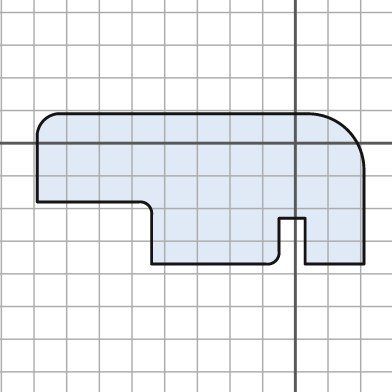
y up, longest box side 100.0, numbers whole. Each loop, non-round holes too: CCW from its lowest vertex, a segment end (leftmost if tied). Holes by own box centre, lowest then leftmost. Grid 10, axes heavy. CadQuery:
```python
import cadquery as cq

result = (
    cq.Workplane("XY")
    .moveTo(-44.0, -37.0)
    .lineTo(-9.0, -37.0)
    .threePointArc((-6.0, -36.0), (-5.0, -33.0))
    .lineTo(-5.0, -23.0)
    .lineTo(3.0, -23.0)
    .lineTo(3.0, -37.0)
    .lineTo(21.0, -37.0)
    .lineTo(21.0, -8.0)
    .threePointArc((16.0, 4.0), (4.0, 9.0))
    .lineTo(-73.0, 9.0)
    .threePointArc((-77.0, 7.0), (-79.0, 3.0))
    .lineTo(-79.0, -18.0)
    .lineTo(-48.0, -18.0)
    .threePointArc((-45.0, -19.0), (-44.0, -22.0))
    .close()
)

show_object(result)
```